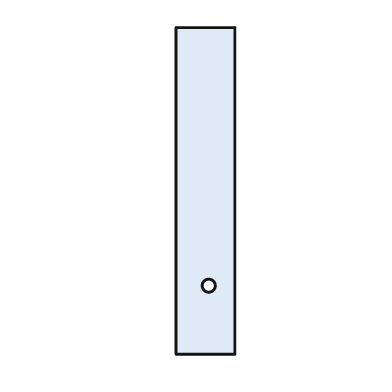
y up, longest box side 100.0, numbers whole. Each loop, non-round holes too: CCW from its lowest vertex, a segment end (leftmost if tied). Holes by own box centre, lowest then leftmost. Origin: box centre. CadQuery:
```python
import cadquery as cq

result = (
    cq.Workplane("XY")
    .moveTo(-9.0, -50.0)
    .lineTo(9.0, -50.0)
    .lineTo(9.0, 50.0)
    .lineTo(-9.0, 50.0)
    .close()
    .moveTo(1.0, -29.0)
    .circle(2.0)
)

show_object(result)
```